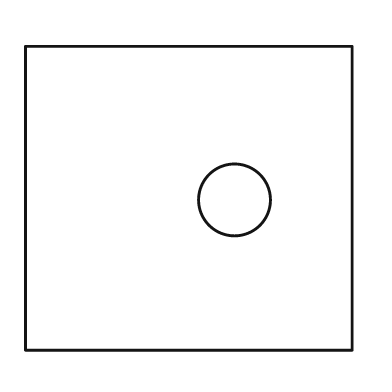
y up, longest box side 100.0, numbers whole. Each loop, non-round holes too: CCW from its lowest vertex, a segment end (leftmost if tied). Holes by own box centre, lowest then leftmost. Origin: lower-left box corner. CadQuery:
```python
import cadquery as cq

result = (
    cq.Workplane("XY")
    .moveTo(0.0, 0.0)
    .lineTo(100.0, 0.0)
    .lineTo(100.0, 93.0)
    .lineTo(0.0, 93.0)
    .close()
    .moveTo(64.0, 46.0)
    .circle(11.0)
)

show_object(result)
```